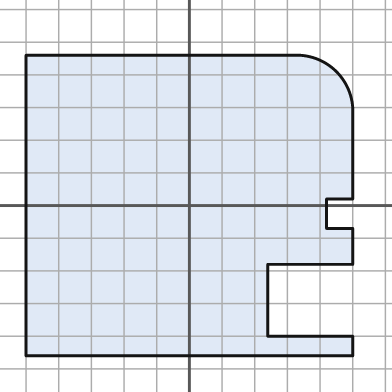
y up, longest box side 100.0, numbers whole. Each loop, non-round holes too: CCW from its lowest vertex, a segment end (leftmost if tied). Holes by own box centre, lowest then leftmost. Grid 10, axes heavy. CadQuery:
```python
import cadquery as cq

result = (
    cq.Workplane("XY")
    .moveTo(-50.0, -46.0)
    .lineTo(50.0, -46.0)
    .lineTo(50.0, -40.0)
    .lineTo(24.0, -40.0)
    .lineTo(24.0, -18.0)
    .lineTo(50.0, -18.0)
    .lineTo(50.0, -7.0)
    .lineTo(42.0, -7.0)
    .lineTo(42.0, 2.0)
    .lineTo(50.0, 2.0)
    .lineTo(50.0, 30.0)
    .threePointArc((45.0, 41.0), (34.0, 46.0))
    .lineTo(-50.0, 46.0)
    .close()
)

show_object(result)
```